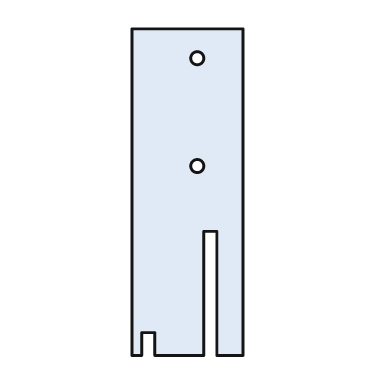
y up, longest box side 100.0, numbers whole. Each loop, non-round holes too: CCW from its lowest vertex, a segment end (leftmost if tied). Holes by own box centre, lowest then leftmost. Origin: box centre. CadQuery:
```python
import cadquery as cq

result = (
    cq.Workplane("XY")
    .moveTo(-17.0, -50.0)
    .lineTo(-14.0, -50.0)
    .lineTo(-14.0, -43.0)
    .lineTo(-10.0, -43.0)
    .lineTo(-10.0, -50.0)
    .lineTo(5.0, -50.0)
    .lineTo(5.0, -12.0)
    .lineTo(9.0, -12.0)
    .lineTo(9.0, -50.0)
    .lineTo(17.0, -50.0)
    .lineTo(17.0, 50.0)
    .lineTo(-17.0, 50.0)
    .close()
    .moveTo(3.0, 8.0)
    .circle(2.0)
    .moveTo(3.0, 41.0)
    .circle(2.0)
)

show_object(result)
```